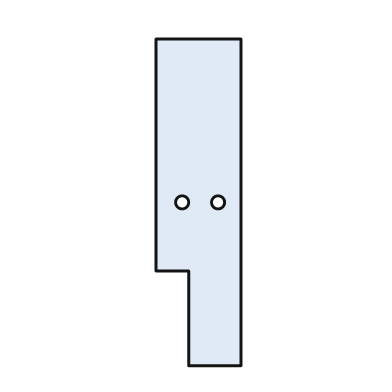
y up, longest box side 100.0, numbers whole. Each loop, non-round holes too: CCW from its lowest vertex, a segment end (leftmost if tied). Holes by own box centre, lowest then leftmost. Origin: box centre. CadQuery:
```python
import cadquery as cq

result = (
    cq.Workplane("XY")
    .moveTo(-3.0, -50.0)
    .lineTo(13.0, -50.0)
    .lineTo(13.0, 50.0)
    .lineTo(-13.0, 50.0)
    .lineTo(-13.0, -21.0)
    .lineTo(-3.0, -21.0)
    .close()
    .moveTo(-5.0, 0.0)
    .circle(2.0)
    .moveTo(6.0, 0.0)
    .circle(2.0)
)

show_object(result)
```